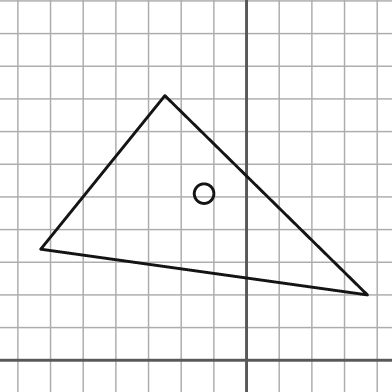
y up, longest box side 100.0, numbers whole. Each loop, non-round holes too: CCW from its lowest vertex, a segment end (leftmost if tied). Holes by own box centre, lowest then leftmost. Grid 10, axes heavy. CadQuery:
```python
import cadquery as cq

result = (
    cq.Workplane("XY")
    .moveTo(37.0, 20.0)
    .lineTo(-25.0, 81.0)
    .lineTo(-63.0, 34.0)
    .close()
    .moveTo(-13.0, 51.0)
    .circle(3.0)
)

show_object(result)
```